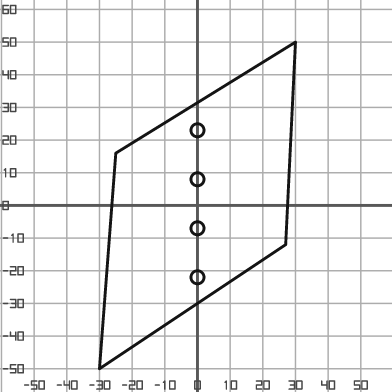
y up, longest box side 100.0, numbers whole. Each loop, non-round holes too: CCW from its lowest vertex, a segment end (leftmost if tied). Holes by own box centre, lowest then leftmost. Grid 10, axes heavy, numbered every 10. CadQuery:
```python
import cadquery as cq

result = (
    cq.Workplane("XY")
    .moveTo(-30.0, -50.0)
    .lineTo(27.0, -12.0)
    .lineTo(30.0, 50.0)
    .lineTo(-25.0, 16.0)
    .close()
    .moveTo(0.0, -22.0)
    .circle(2.0)
    .moveTo(0.0, -7.0)
    .circle(2.0)
    .moveTo(0.0, 8.0)
    .circle(2.0)
    .moveTo(0.0, 23.0)
    .circle(2.0)
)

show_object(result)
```